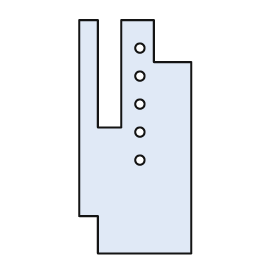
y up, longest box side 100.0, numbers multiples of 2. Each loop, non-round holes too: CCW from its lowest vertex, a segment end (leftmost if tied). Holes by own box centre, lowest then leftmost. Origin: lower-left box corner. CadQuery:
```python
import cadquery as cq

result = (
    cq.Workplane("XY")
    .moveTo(8.0, 0.0)
    .lineTo(48.0, 0.0)
    .lineTo(48.0, 82.0)
    .lineTo(32.0, 82.0)
    .lineTo(32.0, 100.0)
    .lineTo(18.0, 100.0)
    .lineTo(18.0, 54.0)
    .lineTo(8.0, 54.0)
    .lineTo(8.0, 100.0)
    .lineTo(0.0, 100.0)
    .lineTo(0.0, 16.0)
    .lineTo(8.0, 16.0)
    .close()
    .moveTo(26.0, 40.0)
    .circle(2.0)
    .moveTo(26.0, 52.0)
    .circle(2.0)
    .moveTo(26.0, 64.0)
    .circle(2.0)
    .moveTo(26.0, 76.0)
    .circle(2.0)
    .moveTo(26.0, 88.0)
    .circle(2.0)
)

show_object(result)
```